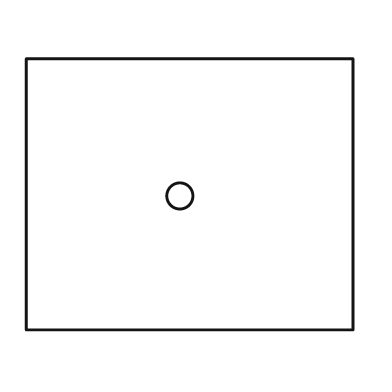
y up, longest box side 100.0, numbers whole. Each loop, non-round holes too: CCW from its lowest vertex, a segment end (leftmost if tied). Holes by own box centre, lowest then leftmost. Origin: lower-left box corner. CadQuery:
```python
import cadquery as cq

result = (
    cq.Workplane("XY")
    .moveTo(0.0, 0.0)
    .lineTo(100.0, 0.0)
    .lineTo(100.0, 83.0)
    .lineTo(0.0, 83.0)
    .close()
    .moveTo(47.0, 41.0)
    .circle(4.0)
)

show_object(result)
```